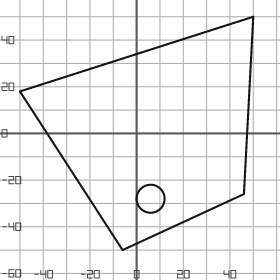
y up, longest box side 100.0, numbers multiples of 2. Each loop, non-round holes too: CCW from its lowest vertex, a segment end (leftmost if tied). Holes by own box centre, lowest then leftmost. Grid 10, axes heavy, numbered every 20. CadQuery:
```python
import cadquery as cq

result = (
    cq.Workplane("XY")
    .moveTo(-6.0, -50.0)
    .lineTo(46.0, -26.0)
    .lineTo(50.0, 50.0)
    .lineTo(-50.0, 18.0)
    .close()
    .moveTo(6.0, -28.0)
    .circle(6.0)
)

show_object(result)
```